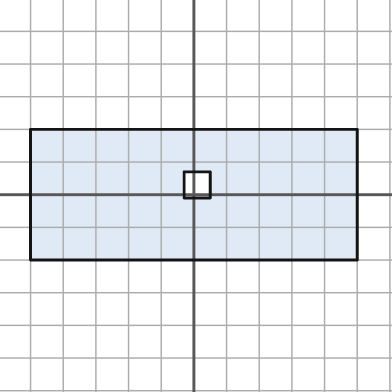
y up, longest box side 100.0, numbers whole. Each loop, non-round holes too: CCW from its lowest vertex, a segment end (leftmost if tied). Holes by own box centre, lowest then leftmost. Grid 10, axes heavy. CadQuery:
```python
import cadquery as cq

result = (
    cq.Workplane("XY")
    .moveTo(-50.0, -20.0)
    .lineTo(50.0, -20.0)
    .lineTo(50.0, 20.0)
    .lineTo(-50.0, 20.0)
    .close()
    .moveTo(-3.0, -1.0)
    .lineTo(5.0, -1.0)
    .lineTo(5.0, 7.0)
    .lineTo(-3.0, 7.0)
    .close()
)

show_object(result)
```